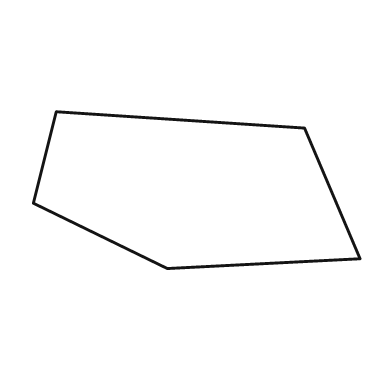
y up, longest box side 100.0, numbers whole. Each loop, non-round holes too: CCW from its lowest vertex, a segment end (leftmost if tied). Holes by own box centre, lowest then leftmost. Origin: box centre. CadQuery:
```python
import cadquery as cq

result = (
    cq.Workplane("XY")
    .moveTo(-9.0, -24.0)
    .lineTo(50.0, -21.0)
    .lineTo(33.0, 19.0)
    .lineTo(-43.0, 24.0)
    .lineTo(-50.0, -4.0)
    .close()
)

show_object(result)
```